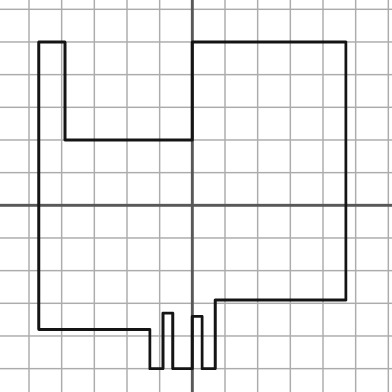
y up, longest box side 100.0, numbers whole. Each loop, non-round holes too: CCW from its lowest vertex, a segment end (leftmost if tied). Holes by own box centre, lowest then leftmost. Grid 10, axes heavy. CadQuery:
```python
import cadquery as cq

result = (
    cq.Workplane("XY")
    .moveTo(-13.0, -50.0)
    .lineTo(-9.0, -50.0)
    .lineTo(-9.0, -33.0)
    .lineTo(-6.0, -33.0)
    .lineTo(-6.0, -50.0)
    .lineTo(0.0, -50.0)
    .lineTo(0.0, -34.0)
    .lineTo(3.0, -34.0)
    .lineTo(3.0, -50.0)
    .lineTo(7.0, -50.0)
    .lineTo(7.0, -29.0)
    .lineTo(47.0, -29.0)
    .lineTo(47.0, 50.0)
    .lineTo(0.0, 50.0)
    .lineTo(0.0, 20.0)
    .lineTo(-39.0, 20.0)
    .lineTo(-39.0, 50.0)
    .lineTo(-47.0, 50.0)
    .lineTo(-47.0, -38.0)
    .lineTo(-13.0, -38.0)
    .close()
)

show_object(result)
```